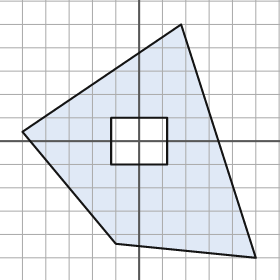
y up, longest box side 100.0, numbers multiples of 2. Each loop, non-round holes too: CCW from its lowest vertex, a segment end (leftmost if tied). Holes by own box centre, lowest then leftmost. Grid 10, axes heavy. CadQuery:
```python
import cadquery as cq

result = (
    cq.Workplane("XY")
    .moveTo(50.0, -50.0)
    .lineTo(18.0, 50.0)
    .lineTo(-50.0, 4.0)
    .lineTo(-10.0, -44.0)
    .close()
    .moveTo(-12.0, -10.0)
    .lineTo(12.0, -10.0)
    .lineTo(12.0, 10.0)
    .lineTo(-12.0, 10.0)
    .close()
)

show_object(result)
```